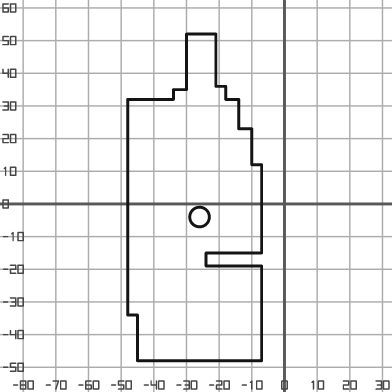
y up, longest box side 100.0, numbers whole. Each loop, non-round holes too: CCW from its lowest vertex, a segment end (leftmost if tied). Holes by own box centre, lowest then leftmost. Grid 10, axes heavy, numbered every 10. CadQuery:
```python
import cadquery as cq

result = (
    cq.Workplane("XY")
    .moveTo(-45.0, -48.0)
    .lineTo(-7.0, -48.0)
    .lineTo(-7.0, -19.0)
    .lineTo(-24.0, -19.0)
    .lineTo(-24.0, -15.0)
    .lineTo(-7.0, -15.0)
    .lineTo(-7.0, 12.0)
    .lineTo(-10.0, 12.0)
    .lineTo(-10.0, 23.0)
    .lineTo(-14.0, 23.0)
    .lineTo(-14.0, 32.0)
    .lineTo(-18.0, 32.0)
    .lineTo(-18.0, 36.0)
    .lineTo(-21.0, 36.0)
    .lineTo(-21.0, 52.0)
    .lineTo(-30.0, 52.0)
    .lineTo(-30.0, 35.0)
    .lineTo(-34.0, 35.0)
    .lineTo(-34.0, 32.0)
    .lineTo(-48.0, 32.0)
    .lineTo(-48.0, -34.0)
    .lineTo(-45.0, -34.0)
    .close()
    .moveTo(-26.0, -4.0)
    .circle(3.0)
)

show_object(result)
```